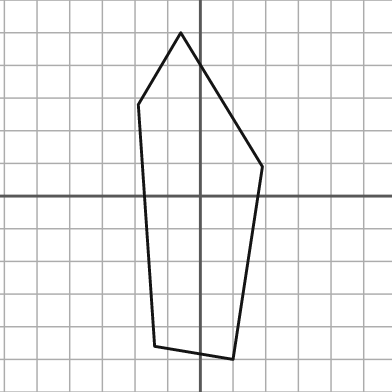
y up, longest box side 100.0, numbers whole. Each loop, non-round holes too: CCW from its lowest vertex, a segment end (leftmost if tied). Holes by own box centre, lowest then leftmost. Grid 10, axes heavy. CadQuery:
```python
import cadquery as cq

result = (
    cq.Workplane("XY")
    .moveTo(10.0, -50.0)
    .lineTo(19.0, 9.0)
    .lineTo(-6.0, 50.0)
    .lineTo(-19.0, 28.0)
    .lineTo(-14.0, -46.0)
    .close()
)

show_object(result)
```